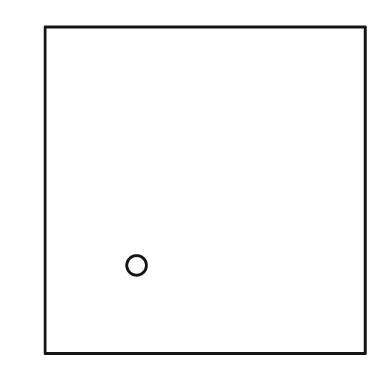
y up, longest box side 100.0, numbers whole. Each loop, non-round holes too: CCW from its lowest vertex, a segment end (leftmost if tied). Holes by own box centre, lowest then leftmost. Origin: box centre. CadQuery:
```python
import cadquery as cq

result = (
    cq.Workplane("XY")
    .moveTo(-49.0, -50.0)
    .lineTo(49.0, -50.0)
    .lineTo(49.0, 50.0)
    .lineTo(-49.0, 50.0)
    .close()
    .moveTo(-21.0, -23.0)
    .circle(3.0)
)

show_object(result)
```